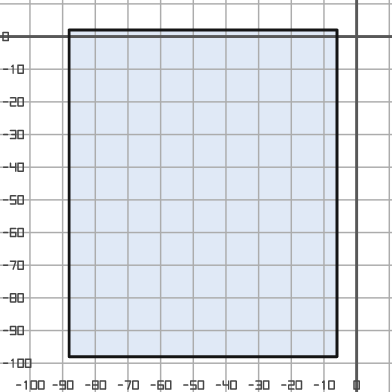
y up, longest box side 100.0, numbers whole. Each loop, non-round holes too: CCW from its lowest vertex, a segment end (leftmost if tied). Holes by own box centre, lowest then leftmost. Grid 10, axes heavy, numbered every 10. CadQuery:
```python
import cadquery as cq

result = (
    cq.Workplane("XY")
    .moveTo(-88.0, -98.0)
    .lineTo(-6.0, -98.0)
    .lineTo(-6.0, 2.0)
    .lineTo(-88.0, 2.0)
    .close()
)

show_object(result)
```